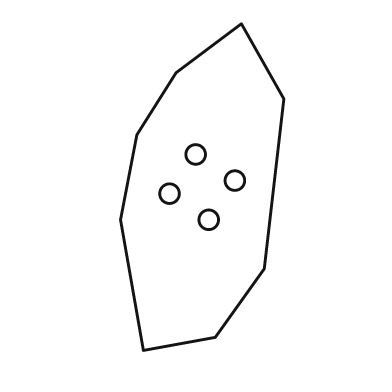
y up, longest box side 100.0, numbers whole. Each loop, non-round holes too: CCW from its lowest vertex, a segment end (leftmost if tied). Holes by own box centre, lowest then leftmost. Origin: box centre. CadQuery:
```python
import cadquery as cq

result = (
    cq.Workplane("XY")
    .moveTo(-18.0, -50.0)
    .lineTo(4.0, -46.0)
    .lineTo(19.0, -25.0)
    .lineTo(25.0, 27.0)
    .lineTo(12.0, 50.0)
    .lineTo(-8.0, 35.0)
    .lineTo(-20.0, 16.0)
    .lineTo(-25.0, -10.0)
    .close()
    .moveTo(2.0, -10.0)
    .circle(3.0)
    .moveTo(-10.0, -2.0)
    .circle(3.0)
    .moveTo(10.0, 2.0)
    .circle(3.0)
    .moveTo(-2.0, 10.0)
    .circle(3.0)
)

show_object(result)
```